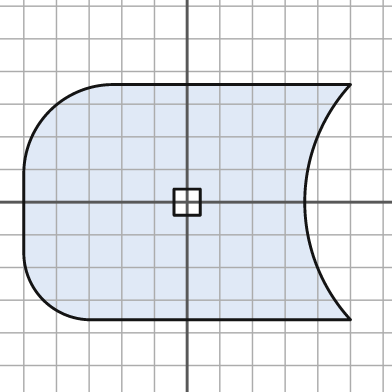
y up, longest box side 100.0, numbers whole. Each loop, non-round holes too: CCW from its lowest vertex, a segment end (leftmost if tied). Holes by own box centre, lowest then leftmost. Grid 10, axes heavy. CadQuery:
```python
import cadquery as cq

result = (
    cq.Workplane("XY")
    .moveTo(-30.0, -36.0)
    .lineTo(50.0, -36.0)
    .threePointArc((36.0, 0.0), (50.0, 36.0))
    .lineTo(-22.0, 36.0)
    .threePointArc((-42.0, 28.0), (-50.0, 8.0))
    .lineTo(-50.0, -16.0)
    .threePointArc((-44.0, -30.0), (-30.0, -36.0))
    .close()
    .moveTo(-4.0, -4.0)
    .lineTo(4.0, -4.0)
    .lineTo(4.0, 4.0)
    .lineTo(-4.0, 4.0)
    .close()
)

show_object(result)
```